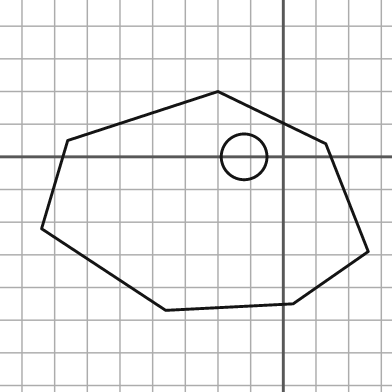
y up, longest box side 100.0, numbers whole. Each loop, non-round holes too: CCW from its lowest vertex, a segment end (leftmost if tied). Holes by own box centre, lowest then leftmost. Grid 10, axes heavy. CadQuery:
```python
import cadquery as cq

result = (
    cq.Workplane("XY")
    .moveTo(-36.0, -47.0)
    .lineTo(3.0, -45.0)
    .lineTo(26.0, -29.0)
    .lineTo(13.0, 4.0)
    .lineTo(-20.0, 20.0)
    .lineTo(-66.0, 5.0)
    .lineTo(-74.0, -22.0)
    .close()
    .moveTo(-12.0, 0.0)
    .circle(7.0)
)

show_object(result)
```